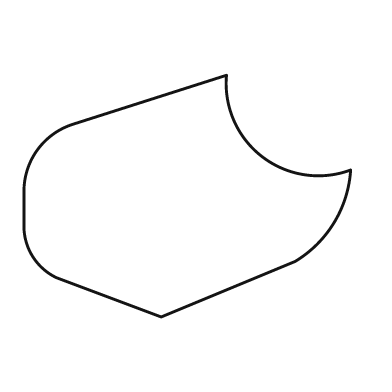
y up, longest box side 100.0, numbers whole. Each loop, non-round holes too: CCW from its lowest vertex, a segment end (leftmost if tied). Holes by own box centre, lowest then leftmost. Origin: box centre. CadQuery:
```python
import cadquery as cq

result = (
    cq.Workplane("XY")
    .moveTo(-8.0, -37.0)
    .lineTo(33.0, -20.0)
    .threePointArc((45.0, -8.0), (50.0, 8.0))
    .threePointArc((23.0, 12.0), (12.0, 37.0))
    .lineTo(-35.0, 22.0)
    .threePointArc((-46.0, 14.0), (-50.0, 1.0))
    .lineTo(-50.0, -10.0)
    .threePointArc((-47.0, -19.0), (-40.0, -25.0))
    .close()
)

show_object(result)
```